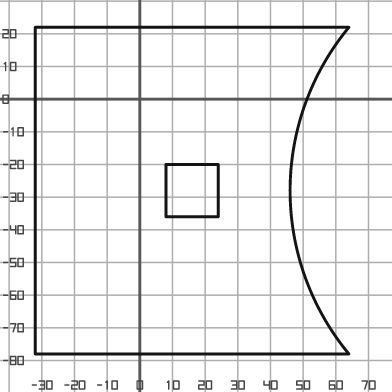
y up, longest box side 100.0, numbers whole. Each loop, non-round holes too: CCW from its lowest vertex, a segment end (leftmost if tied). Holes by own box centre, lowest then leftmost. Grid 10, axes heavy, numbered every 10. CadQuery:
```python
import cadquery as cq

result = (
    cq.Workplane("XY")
    .moveTo(-32.0, -78.0)
    .lineTo(64.0, -78.0)
    .threePointArc((46.0, -28.0), (64.0, 22.0))
    .lineTo(-32.0, 22.0)
    .close()
    .moveTo(8.0, -36.0)
    .lineTo(24.0, -36.0)
    .lineTo(24.0, -20.0)
    .lineTo(8.0, -20.0)
    .close()
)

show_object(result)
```